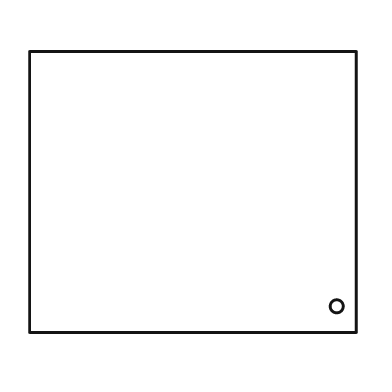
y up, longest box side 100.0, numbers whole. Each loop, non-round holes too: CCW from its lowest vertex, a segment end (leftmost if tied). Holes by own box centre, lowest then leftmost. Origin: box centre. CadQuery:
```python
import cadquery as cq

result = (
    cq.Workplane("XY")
    .moveTo(-50.0, -43.0)
    .lineTo(50.0, -43.0)
    .lineTo(50.0, 43.0)
    .lineTo(-50.0, 43.0)
    .close()
    .moveTo(44.0, -35.0)
    .circle(2.0)
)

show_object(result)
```